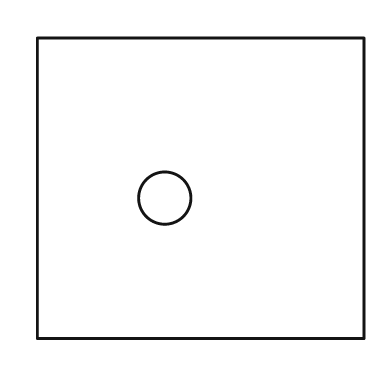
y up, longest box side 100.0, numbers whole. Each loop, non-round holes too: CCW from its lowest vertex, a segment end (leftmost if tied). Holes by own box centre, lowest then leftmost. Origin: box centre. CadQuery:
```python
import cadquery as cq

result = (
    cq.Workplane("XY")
    .moveTo(-50.0, -46.0)
    .lineTo(50.0, -46.0)
    .lineTo(50.0, 46.0)
    .lineTo(-50.0, 46.0)
    .close()
    .moveTo(-11.0, -3.0)
    .circle(8.0)
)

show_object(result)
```